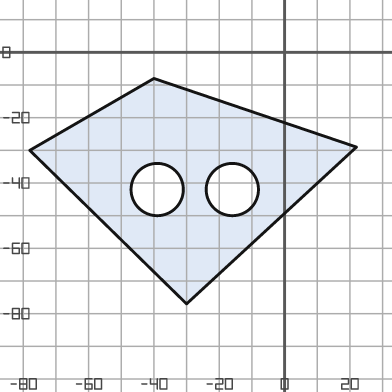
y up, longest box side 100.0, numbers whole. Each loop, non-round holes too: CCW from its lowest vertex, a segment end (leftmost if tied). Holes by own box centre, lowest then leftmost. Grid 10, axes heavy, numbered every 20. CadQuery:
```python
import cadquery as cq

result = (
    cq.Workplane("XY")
    .moveTo(-30.0, -77.0)
    .lineTo(22.0, -29.0)
    .lineTo(-40.0, -8.0)
    .lineTo(-78.0, -30.0)
    .close()
    .moveTo(-39.0, -42.0)
    .circle(8.0)
    .moveTo(-16.0, -42.0)
    .circle(8.0)
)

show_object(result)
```